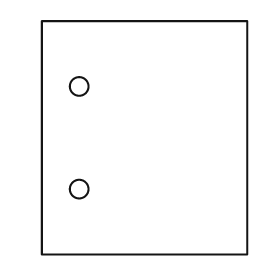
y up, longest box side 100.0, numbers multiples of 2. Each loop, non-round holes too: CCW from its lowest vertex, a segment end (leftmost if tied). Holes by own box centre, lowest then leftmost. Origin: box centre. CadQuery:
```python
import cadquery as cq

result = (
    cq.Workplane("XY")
    .moveTo(-44.0, -50.0)
    .lineTo(44.0, -50.0)
    .lineTo(44.0, 50.0)
    .lineTo(-44.0, 50.0)
    .close()
    .moveTo(-28.0, -22.0)
    .circle(4.0)
    .moveTo(-28.0, 22.0)
    .circle(4.0)
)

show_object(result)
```